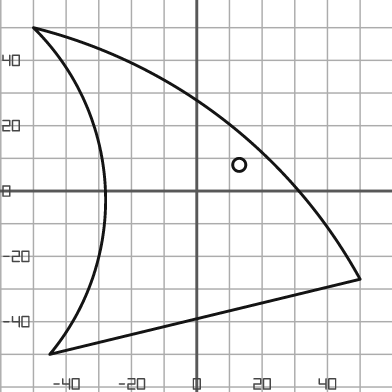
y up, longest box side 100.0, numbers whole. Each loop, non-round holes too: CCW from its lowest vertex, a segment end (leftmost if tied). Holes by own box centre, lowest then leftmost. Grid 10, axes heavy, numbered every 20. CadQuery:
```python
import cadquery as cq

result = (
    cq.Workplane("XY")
    .moveTo(-45.0, -50.0)
    .lineTo(50.0, -27.0)
    .threePointArc((8.0, 22.0), (-50.0, 50.0))
    .threePointArc((-28.0, 1.0), (-45.0, -50.0))
    .close()
    .moveTo(13.0, 8.0)
    .circle(2.0)
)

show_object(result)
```